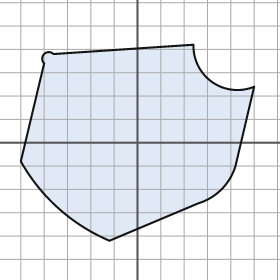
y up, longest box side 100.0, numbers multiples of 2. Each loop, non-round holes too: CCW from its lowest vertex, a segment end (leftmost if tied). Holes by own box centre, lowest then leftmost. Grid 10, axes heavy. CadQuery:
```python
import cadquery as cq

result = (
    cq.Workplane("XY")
    .moveTo(-12.0, -42.0)
    .lineTo(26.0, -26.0)
    .threePointArc((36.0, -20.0), (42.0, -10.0))
    .lineTo(50.0, 24.0)
    .threePointArc((32.0, 26.0), (24.0, 42.0))
    .lineTo(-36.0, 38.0)
    .threePointArc((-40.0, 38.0), (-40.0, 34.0))
    .lineTo(-50.0, -8.0)
    .threePointArc((-34.0, -28.0), (-12.0, -42.0))
    .close()
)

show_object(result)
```